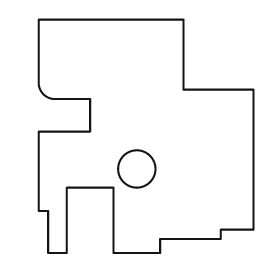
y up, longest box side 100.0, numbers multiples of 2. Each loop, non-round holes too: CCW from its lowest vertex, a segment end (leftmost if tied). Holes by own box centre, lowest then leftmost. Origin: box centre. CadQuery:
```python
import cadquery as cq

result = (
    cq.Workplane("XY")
    .moveTo(-42.0, -50.0)
    .lineTo(-34.0, -50.0)
    .lineTo(-34.0, -22.0)
    .lineTo(-14.0, -22.0)
    .lineTo(-14.0, -50.0)
    .lineTo(6.0, -50.0)
    .lineTo(6.0, -44.0)
    .lineTo(32.0, -44.0)
    .lineTo(32.0, -40.0)
    .lineTo(46.0, -40.0)
    .lineTo(46.0, 20.0)
    .lineTo(16.0, 20.0)
    .lineTo(16.0, 50.0)
    .lineTo(-46.0, 50.0)
    .lineTo(-46.0, 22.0)
    .threePointArc((-44.0, 18.0), (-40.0, 16.0))
    .lineTo(-24.0, 16.0)
    .lineTo(-24.0, 2.0)
    .lineTo(-46.0, 2.0)
    .lineTo(-46.0, -32.0)
    .lineTo(-42.0, -32.0)
    .close()
    .moveTo(-4.0, -14.0)
    .circle(8.0)
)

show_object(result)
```